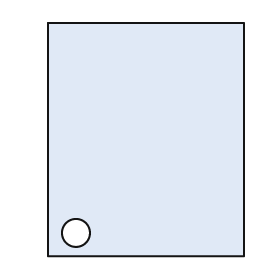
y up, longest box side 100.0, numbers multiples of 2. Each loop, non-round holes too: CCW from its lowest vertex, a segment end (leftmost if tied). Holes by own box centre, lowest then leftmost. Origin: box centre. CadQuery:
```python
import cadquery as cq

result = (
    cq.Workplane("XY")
    .moveTo(-42.0, -50.0)
    .lineTo(42.0, -50.0)
    .lineTo(42.0, 50.0)
    .lineTo(-42.0, 50.0)
    .close()
    .moveTo(-30.0, -40.0)
    .circle(6.0)
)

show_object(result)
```